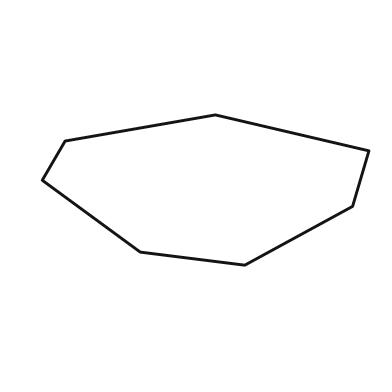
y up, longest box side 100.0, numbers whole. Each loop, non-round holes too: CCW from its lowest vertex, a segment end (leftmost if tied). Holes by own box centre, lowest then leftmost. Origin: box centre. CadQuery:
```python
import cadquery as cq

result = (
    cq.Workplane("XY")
    .moveTo(12.0, -23.0)
    .lineTo(45.0, -5.0)
    .lineTo(50.0, 12.0)
    .lineTo(3.0, 23.0)
    .lineTo(-43.0, 15.0)
    .lineTo(-50.0, 3.0)
    .lineTo(-20.0, -19.0)
    .close()
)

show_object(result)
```